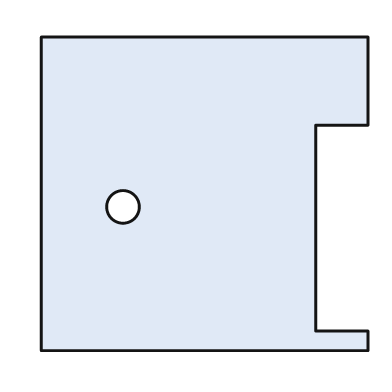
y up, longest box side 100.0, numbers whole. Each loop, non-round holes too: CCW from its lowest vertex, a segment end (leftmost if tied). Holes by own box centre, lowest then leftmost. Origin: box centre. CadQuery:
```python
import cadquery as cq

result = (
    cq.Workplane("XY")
    .moveTo(-50.0, -48.0)
    .lineTo(50.0, -48.0)
    .lineTo(50.0, -42.0)
    .lineTo(34.0, -42.0)
    .lineTo(34.0, 21.0)
    .lineTo(50.0, 21.0)
    .lineTo(50.0, 48.0)
    .lineTo(-50.0, 48.0)
    .close()
    .moveTo(-25.0, -4.0)
    .circle(5.0)
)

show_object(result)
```